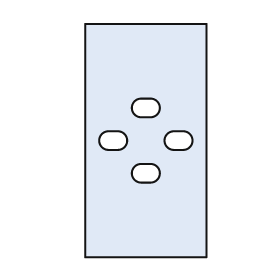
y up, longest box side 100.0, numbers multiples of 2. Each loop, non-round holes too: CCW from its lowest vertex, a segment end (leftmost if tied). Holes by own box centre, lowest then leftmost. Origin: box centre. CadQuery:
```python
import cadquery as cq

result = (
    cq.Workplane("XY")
    .moveTo(-26.0, -50.0)
    .lineTo(26.0, -50.0)
    .lineTo(26.0, 50.0)
    .lineTo(-26.0, 50.0)
    .close()
    .moveTo(-2.0, -18.0)
    .lineTo(2.0, -18.0)
    .threePointArc((6.0, -14.0), (2.0, -10.0))
    .lineTo(-2.0, -10.0)
    .threePointArc((-6.0, -14.0), (-2.0, -18.0))
    .close()
    .moveTo(-16.0, -4.0)
    .lineTo(-12.0, -4.0)
    .threePointArc((-8.0, 0.0), (-12.0, 4.0))
    .lineTo(-16.0, 4.0)
    .threePointArc((-20.0, 0.0), (-16.0, -4.0))
    .close()
    .moveTo(12.0, -4.0)
    .lineTo(16.0, -4.0)
    .threePointArc((20.0, 0.0), (16.0, 4.0))
    .lineTo(12.0, 4.0)
    .threePointArc((8.0, 0.0), (12.0, -4.0))
    .close()
    .moveTo(-2.0, 10.0)
    .lineTo(2.0, 10.0)
    .threePointArc((6.0, 14.0), (2.0, 18.0))
    .lineTo(-2.0, 18.0)
    .threePointArc((-6.0, 14.0), (-2.0, 10.0))
    .close()
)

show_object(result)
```